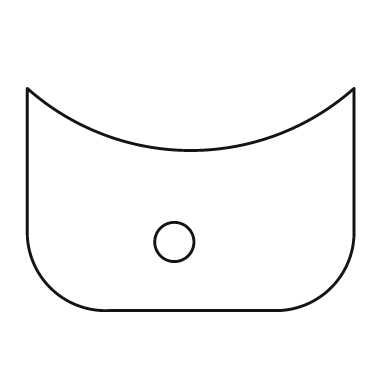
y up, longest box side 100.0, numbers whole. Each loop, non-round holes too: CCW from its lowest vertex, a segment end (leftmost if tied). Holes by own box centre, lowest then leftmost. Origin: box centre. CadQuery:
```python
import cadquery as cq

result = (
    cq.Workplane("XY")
    .moveTo(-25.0, -34.0)
    .lineTo(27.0, -34.0)
    .threePointArc((43.0, -27.0), (50.0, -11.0))
    .lineTo(50.0, 34.0)
    .threePointArc((0.0, 15.0), (-50.0, 34.0))
    .lineTo(-50.0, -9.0)
    .threePointArc((-43.0, -27.0), (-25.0, -34.0))
    .close()
    .moveTo(-5.0, -13.0)
    .circle(6.0)
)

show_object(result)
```